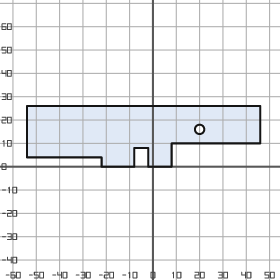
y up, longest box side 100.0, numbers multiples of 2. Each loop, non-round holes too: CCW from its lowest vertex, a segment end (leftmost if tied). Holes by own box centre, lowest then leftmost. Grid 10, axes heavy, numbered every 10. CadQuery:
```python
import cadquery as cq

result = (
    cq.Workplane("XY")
    .moveTo(-22.0, 0.0)
    .lineTo(-8.0, 0.0)
    .lineTo(-8.0, 8.0)
    .lineTo(-2.0, 8.0)
    .lineTo(-2.0, 0.0)
    .lineTo(8.0, 0.0)
    .lineTo(8.0, 10.0)
    .lineTo(46.0, 10.0)
    .lineTo(46.0, 26.0)
    .lineTo(-54.0, 26.0)
    .lineTo(-54.0, 4.0)
    .lineTo(-22.0, 4.0)
    .close()
    .moveTo(20.0, 16.0)
    .circle(2.0)
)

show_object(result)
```